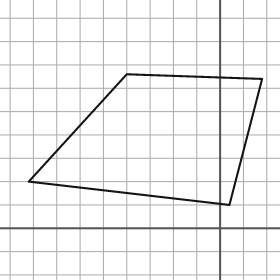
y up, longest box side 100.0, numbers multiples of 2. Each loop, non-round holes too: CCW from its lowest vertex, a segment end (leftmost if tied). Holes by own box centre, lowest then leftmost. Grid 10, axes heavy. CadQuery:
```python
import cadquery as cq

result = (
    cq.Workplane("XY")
    .moveTo(4.0, 10.0)
    .lineTo(18.0, 64.0)
    .lineTo(-40.0, 66.0)
    .lineTo(-82.0, 20.0)
    .close()
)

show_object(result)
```